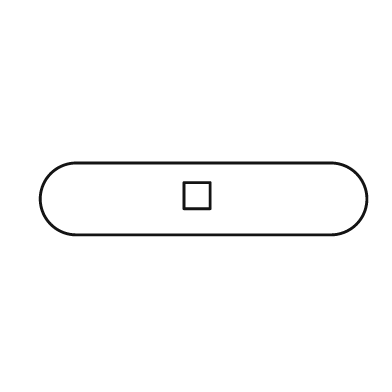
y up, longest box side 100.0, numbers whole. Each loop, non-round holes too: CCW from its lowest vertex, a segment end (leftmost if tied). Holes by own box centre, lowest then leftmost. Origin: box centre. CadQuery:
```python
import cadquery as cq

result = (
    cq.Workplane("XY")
    .moveTo(-39.0, -11.0)
    .lineTo(39.0, -11.0)
    .threePointArc((50.0, 0.0), (39.0, 11.0))
    .lineTo(-39.0, 11.0)
    .threePointArc((-50.0, 0.0), (-39.0, -11.0))
    .close()
    .moveTo(-6.0, -3.0)
    .lineTo(2.0, -3.0)
    .lineTo(2.0, 5.0)
    .lineTo(-6.0, 5.0)
    .close()
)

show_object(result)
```